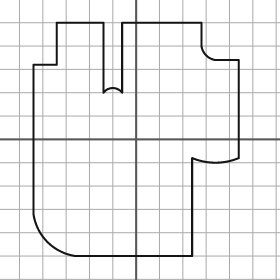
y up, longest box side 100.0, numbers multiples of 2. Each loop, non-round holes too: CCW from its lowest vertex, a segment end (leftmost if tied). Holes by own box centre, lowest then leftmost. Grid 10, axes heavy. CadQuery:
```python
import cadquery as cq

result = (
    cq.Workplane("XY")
    .moveTo(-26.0, -50.0)
    .lineTo(24.0, -50.0)
    .lineTo(24.0, -8.0)
    .threePointArc((34.0, -10.0), (44.0, -8.0))
    .lineTo(44.0, 34.0)
    .lineTo(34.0, 34.0)
    .threePointArc((30.0, 36.0), (28.0, 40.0))
    .lineTo(28.0, 50.0)
    .lineTo(-6.0, 50.0)
    .lineTo(-6.0, 20.0)
    .threePointArc((-10.0, 22.0), (-14.0, 20.0))
    .lineTo(-14.0, 50.0)
    .lineTo(-34.0, 50.0)
    .lineTo(-34.0, 32.0)
    .lineTo(-44.0, 32.0)
    .lineTo(-44.0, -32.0)
    .threePointArc((-38.0, -44.0), (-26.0, -50.0))
    .close()
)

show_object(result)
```